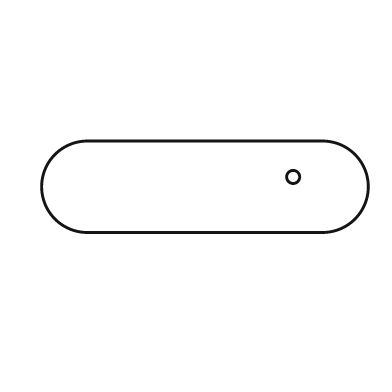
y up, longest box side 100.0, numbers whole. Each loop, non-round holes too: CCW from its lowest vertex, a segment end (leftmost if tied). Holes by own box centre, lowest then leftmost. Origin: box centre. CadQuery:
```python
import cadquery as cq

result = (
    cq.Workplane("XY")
    .moveTo(-36.0, -14.0)
    .lineTo(36.0, -14.0)
    .threePointArc((50.0, 0.0), (36.0, 14.0))
    .lineTo(-36.0, 14.0)
    .threePointArc((-50.0, 0.0), (-36.0, -14.0))
    .close()
    .moveTo(27.0, 3.0)
    .circle(2.0)
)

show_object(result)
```